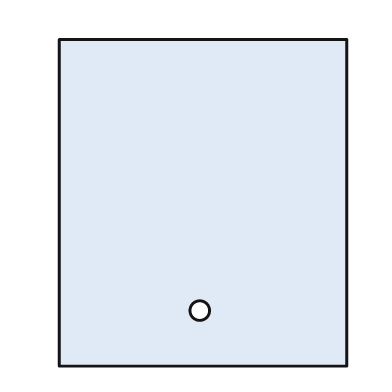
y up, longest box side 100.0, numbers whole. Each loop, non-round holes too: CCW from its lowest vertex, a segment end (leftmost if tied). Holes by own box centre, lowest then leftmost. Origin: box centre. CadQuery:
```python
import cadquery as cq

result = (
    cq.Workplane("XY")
    .moveTo(-44.0, -50.0)
    .lineTo(44.0, -50.0)
    .lineTo(44.0, 50.0)
    .lineTo(-44.0, 50.0)
    .close()
    .moveTo(-1.0, -33.0)
    .circle(3.0)
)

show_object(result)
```